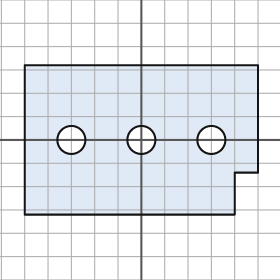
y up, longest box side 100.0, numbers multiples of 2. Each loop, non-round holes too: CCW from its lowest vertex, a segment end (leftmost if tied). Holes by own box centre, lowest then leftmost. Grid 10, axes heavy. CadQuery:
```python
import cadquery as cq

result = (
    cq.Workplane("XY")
    .moveTo(-50.0, -32.0)
    .lineTo(40.0, -32.0)
    .lineTo(40.0, -14.0)
    .lineTo(50.0, -14.0)
    .lineTo(50.0, 32.0)
    .lineTo(-50.0, 32.0)
    .close()
    .moveTo(-30.0, 0.0)
    .circle(6.0)
    .moveTo(0.0, 0.0)
    .circle(6.0)
    .moveTo(30.0, 0.0)
    .circle(6.0)
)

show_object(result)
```